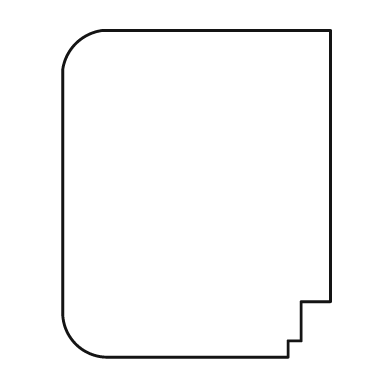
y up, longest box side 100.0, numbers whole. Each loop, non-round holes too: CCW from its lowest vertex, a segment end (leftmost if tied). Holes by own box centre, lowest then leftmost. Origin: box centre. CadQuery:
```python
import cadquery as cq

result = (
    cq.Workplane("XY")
    .moveTo(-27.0, -50.0)
    .lineTo(28.0, -50.0)
    .lineTo(28.0, -45.0)
    .lineTo(32.0, -45.0)
    .lineTo(32.0, -33.0)
    .lineTo(41.0, -33.0)
    .lineTo(41.0, 50.0)
    .lineTo(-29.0, 50.0)
    .threePointArc((-37.0, 46.0), (-41.0, 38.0))
    .lineTo(-41.0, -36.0)
    .threePointArc((-37.0, -46.0), (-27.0, -50.0))
    .close()
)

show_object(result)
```